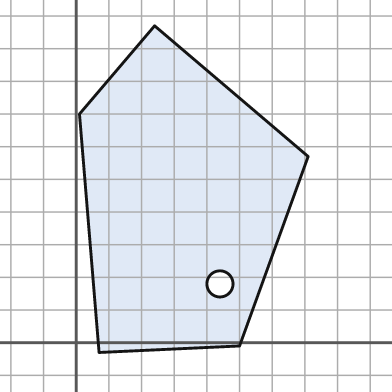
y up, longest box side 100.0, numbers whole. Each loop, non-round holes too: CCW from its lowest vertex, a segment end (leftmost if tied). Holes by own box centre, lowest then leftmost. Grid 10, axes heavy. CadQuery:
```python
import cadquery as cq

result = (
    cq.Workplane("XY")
    .moveTo(7.0, -3.0)
    .lineTo(50.0, -1.0)
    .lineTo(71.0, 57.0)
    .lineTo(24.0, 97.0)
    .lineTo(1.0, 70.0)
    .close()
    .moveTo(44.0, 18.0)
    .circle(4.0)
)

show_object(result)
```